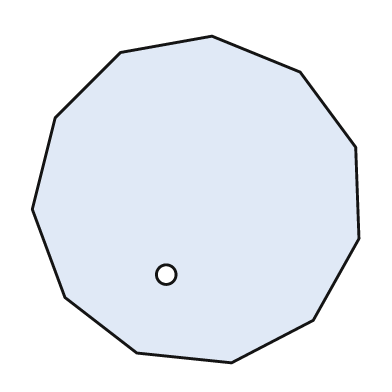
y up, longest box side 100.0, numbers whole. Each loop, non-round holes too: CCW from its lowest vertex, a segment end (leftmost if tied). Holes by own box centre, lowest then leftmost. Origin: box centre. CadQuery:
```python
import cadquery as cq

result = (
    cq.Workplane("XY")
    .moveTo(11.0, -50.0)
    .lineTo(36.0, -37.0)
    .lineTo(50.0, -12.0)
    .lineTo(49.0, 16.0)
    .lineTo(32.0, 39.0)
    .lineTo(5.0, 50.0)
    .lineTo(-23.0, 45.0)
    .lineTo(-43.0, 25.0)
    .lineTo(-50.0, -3.0)
    .lineTo(-40.0, -30.0)
    .lineTo(-18.0, -47.0)
    .close()
    .moveTo(-9.0, -23.0)
    .circle(3.0)
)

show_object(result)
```